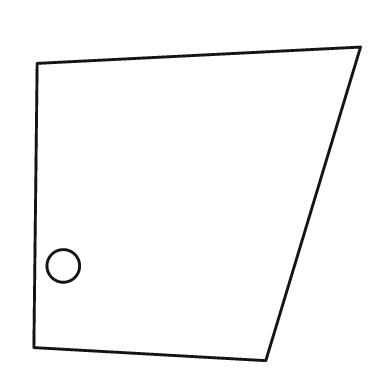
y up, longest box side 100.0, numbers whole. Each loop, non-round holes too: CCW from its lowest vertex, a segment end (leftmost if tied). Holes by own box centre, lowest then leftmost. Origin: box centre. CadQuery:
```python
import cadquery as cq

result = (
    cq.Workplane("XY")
    .moveTo(21.0, -48.0)
    .lineTo(50.0, 48.0)
    .lineTo(-49.0, 43.0)
    .lineTo(-50.0, -44.0)
    .close()
    .moveTo(-41.0, -19.0)
    .circle(5.0)
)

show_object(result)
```